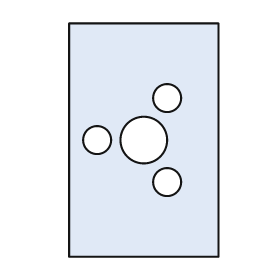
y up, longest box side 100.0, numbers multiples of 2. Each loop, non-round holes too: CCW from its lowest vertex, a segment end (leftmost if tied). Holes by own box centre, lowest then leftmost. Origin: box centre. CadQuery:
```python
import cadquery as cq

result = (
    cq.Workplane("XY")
    .moveTo(-32.0, -50.0)
    .lineTo(32.0, -50.0)
    .lineTo(32.0, 50.0)
    .lineTo(-32.0, 50.0)
    .close()
    .moveTo(10.0, -18.0)
    .circle(6.0)
    .moveTo(-20.0, 0.0)
    .circle(6.0)
    .moveTo(0.0, 0.0)
    .circle(10.0)
    .moveTo(10.0, 18.0)
    .circle(6.0)
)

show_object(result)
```